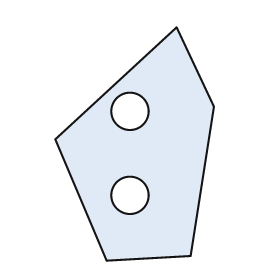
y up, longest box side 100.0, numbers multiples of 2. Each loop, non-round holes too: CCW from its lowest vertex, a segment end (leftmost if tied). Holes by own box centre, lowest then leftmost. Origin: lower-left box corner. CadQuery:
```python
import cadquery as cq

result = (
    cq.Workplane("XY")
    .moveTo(22.0, 0.0)
    .lineTo(58.0, 2.0)
    .lineTo(68.0, 66.0)
    .lineTo(52.0, 100.0)
    .lineTo(0.0, 52.0)
    .close()
    .moveTo(32.0, 28.0)
    .circle(8.0)
    .moveTo(32.0, 64.0)
    .circle(8.0)
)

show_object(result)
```